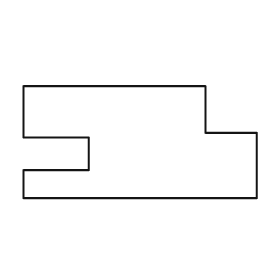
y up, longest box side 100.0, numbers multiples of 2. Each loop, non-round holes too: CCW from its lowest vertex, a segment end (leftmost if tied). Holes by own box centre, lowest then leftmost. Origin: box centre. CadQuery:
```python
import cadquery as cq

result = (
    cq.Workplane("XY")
    .moveTo(-50.0, -24.0)
    .lineTo(50.0, -24.0)
    .lineTo(50.0, 4.0)
    .lineTo(28.0, 4.0)
    .lineTo(28.0, 24.0)
    .lineTo(-50.0, 24.0)
    .lineTo(-50.0, 2.0)
    .lineTo(-22.0, 2.0)
    .lineTo(-22.0, -12.0)
    .lineTo(-50.0, -12.0)
    .close()
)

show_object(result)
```